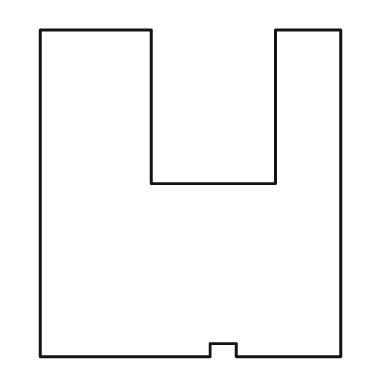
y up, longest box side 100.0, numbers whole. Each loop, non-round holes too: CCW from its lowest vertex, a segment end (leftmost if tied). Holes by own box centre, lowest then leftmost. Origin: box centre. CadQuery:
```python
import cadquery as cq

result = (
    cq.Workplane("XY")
    .moveTo(-46.0, -50.0)
    .lineTo(6.0, -50.0)
    .lineTo(6.0, -46.0)
    .lineTo(14.0, -46.0)
    .lineTo(14.0, -50.0)
    .lineTo(46.0, -50.0)
    .lineTo(46.0, 50.0)
    .lineTo(26.0, 50.0)
    .lineTo(26.0, 3.0)
    .lineTo(-12.0, 3.0)
    .lineTo(-12.0, 50.0)
    .lineTo(-46.0, 50.0)
    .close()
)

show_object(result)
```